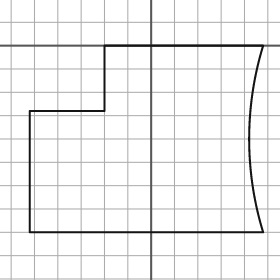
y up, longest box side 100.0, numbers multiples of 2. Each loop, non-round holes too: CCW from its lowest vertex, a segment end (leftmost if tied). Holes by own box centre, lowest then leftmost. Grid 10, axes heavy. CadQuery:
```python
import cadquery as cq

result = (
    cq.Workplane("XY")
    .moveTo(-52.0, -80.0)
    .lineTo(48.0, -80.0)
    .threePointArc((42.0, -40.0), (48.0, 0.0))
    .lineTo(-20.0, 0.0)
    .lineTo(-20.0, -28.0)
    .lineTo(-52.0, -28.0)
    .close()
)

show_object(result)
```